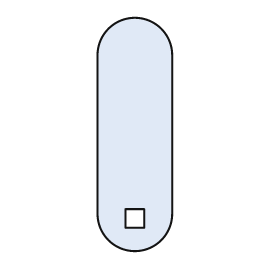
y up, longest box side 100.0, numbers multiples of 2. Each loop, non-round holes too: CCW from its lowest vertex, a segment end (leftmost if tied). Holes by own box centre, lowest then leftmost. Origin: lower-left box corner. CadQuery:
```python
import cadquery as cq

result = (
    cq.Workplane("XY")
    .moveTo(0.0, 16.0)
    .threePointArc((16.0, 0.0), (32.0, 16.0))
    .lineTo(32.0, 84.0)
    .threePointArc((16.0, 100.0), (0.0, 84.0))
    .close()
    .moveTo(12.0, 10.0)
    .lineTo(20.0, 10.0)
    .lineTo(20.0, 18.0)
    .lineTo(12.0, 18.0)
    .close()
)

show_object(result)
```